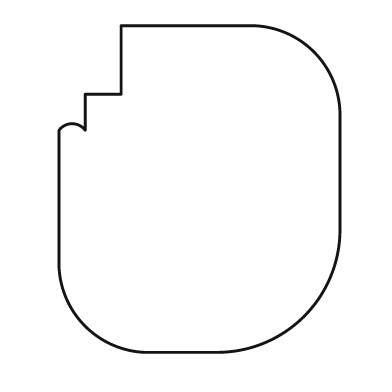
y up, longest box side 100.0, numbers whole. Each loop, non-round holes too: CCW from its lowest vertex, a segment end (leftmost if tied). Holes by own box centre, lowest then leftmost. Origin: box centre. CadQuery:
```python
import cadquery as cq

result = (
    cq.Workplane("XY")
    .moveTo(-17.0, -50.0)
    .lineTo(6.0, -50.0)
    .threePointArc((32.0, -39.0), (43.0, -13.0))
    .lineTo(43.0, 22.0)
    .threePointArc((35.0, 42.0), (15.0, 50.0))
    .lineTo(-24.0, 50.0)
    .lineTo(-24.0, 29.0)
    .lineTo(-35.0, 29.0)
    .lineTo(-35.0, 18.0)
    .threePointArc((-39.0, 20.0), (-43.0, 18.0))
    .lineTo(-43.0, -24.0)
    .threePointArc((-35.0, -42.0), (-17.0, -50.0))
    .close()
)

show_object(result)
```